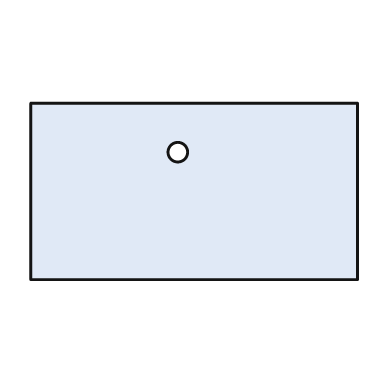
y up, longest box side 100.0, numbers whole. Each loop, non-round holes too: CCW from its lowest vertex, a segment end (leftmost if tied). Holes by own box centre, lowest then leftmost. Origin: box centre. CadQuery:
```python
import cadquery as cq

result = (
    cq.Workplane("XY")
    .moveTo(-50.0, -27.0)
    .lineTo(50.0, -27.0)
    .lineTo(50.0, 27.0)
    .lineTo(-50.0, 27.0)
    .close()
    .moveTo(-5.0, 12.0)
    .circle(3.0)
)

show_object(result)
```